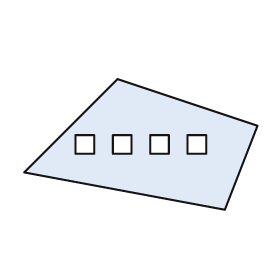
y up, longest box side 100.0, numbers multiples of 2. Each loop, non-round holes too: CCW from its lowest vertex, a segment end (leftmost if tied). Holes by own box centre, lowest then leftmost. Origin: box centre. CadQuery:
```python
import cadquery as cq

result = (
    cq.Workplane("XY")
    .moveTo(36.0, -28.0)
    .lineTo(50.0, 8.0)
    .lineTo(-10.0, 28.0)
    .lineTo(-50.0, -12.0)
    .close()
    .moveTo(-28.0, -4.0)
    .lineTo(-20.0, -4.0)
    .lineTo(-20.0, 4.0)
    .lineTo(-28.0, 4.0)
    .close()
    .moveTo(-12.0, -4.0)
    .lineTo(-4.0, -4.0)
    .lineTo(-4.0, 4.0)
    .lineTo(-12.0, 4.0)
    .close()
    .moveTo(4.0, -4.0)
    .lineTo(12.0, -4.0)
    .lineTo(12.0, 4.0)
    .lineTo(4.0, 4.0)
    .close()
    .moveTo(20.0, -4.0)
    .lineTo(28.0, -4.0)
    .lineTo(28.0, 4.0)
    .lineTo(20.0, 4.0)
    .close()
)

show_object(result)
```